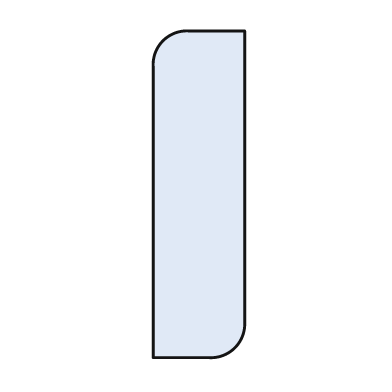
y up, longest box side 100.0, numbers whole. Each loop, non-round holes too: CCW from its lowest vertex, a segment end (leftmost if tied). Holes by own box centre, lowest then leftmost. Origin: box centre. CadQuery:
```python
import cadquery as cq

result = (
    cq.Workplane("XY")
    .moveTo(-14.0, -50.0)
    .lineTo(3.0, -50.0)
    .threePointArc((11.0, -47.0), (14.0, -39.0))
    .lineTo(14.0, 50.0)
    .lineTo(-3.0, 50.0)
    .threePointArc((-11.0, 47.0), (-14.0, 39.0))
    .close()
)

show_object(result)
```